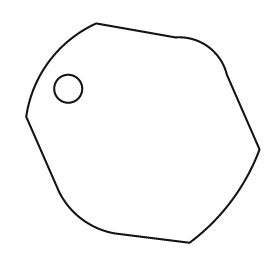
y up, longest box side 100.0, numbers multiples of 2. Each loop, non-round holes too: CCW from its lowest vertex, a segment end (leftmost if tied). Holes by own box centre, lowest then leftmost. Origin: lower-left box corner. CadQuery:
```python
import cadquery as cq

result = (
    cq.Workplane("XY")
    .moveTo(70.0, 0.0)
    .threePointArc((88.0, 18.0), (100.0, 40.0))
    .lineTo(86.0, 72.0)
    .threePointArc((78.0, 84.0), (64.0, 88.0))
    .lineTo(30.0, 94.0)
    .threePointArc((10.0, 78.0), (0.0, 54.0))
    .lineTo(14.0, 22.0)
    .threePointArc((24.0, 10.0), (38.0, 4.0))
    .close()
    .moveTo(18.0, 66.0)
    .circle(6.0)
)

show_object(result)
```